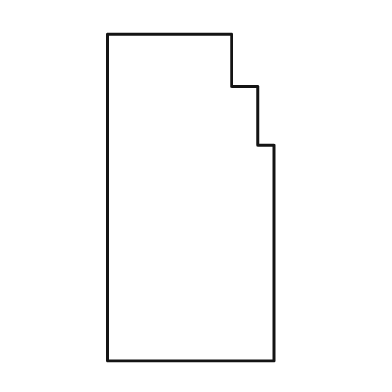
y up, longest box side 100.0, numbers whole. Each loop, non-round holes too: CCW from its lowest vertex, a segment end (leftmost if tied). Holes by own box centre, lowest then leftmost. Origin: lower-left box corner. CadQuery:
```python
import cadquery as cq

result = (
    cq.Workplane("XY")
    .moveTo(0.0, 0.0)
    .lineTo(51.0, 0.0)
    .lineTo(51.0, 66.0)
    .lineTo(46.0, 66.0)
    .lineTo(46.0, 84.0)
    .lineTo(38.0, 84.0)
    .lineTo(38.0, 100.0)
    .lineTo(0.0, 100.0)
    .close()
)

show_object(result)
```